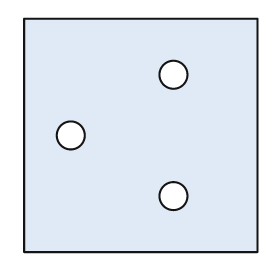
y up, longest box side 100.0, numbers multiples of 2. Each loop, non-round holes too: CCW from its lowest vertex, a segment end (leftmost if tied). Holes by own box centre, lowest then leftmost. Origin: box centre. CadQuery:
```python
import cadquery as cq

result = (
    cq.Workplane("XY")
    .moveTo(-50.0, -50.0)
    .lineTo(50.0, -50.0)
    .lineTo(50.0, 50.0)
    .lineTo(-50.0, 50.0)
    .close()
    .moveTo(14.0, -26.0)
    .circle(6.0)
    .moveTo(-30.0, 0.0)
    .circle(6.0)
    .moveTo(14.0, 26.0)
    .circle(6.0)
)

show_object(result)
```